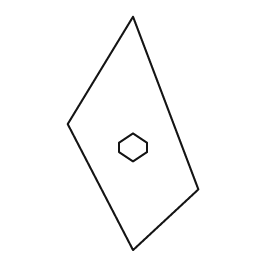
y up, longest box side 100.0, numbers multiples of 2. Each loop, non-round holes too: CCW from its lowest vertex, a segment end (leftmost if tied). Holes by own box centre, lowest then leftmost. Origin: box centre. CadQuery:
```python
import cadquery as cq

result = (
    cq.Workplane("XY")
    .moveTo(0.0, -50.0)
    .lineTo(28.0, -24.0)
    .lineTo(0.0, 50.0)
    .lineTo(-28.0, 4.0)
    .close()
    .moveTo(0.0, -12.0)
    .lineTo(6.0, -8.0)
    .lineTo(6.0, -4.0)
    .lineTo(0.0, 0.0)
    .lineTo(-6.0, -4.0)
    .lineTo(-6.0, -8.0)
    .close()
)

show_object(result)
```